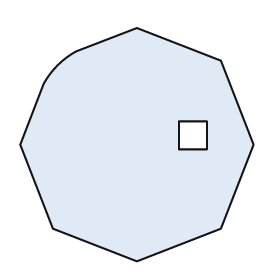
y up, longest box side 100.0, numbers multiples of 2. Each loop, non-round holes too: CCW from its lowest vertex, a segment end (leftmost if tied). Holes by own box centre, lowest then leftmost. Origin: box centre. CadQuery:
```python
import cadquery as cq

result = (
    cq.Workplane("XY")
    .moveTo(0.0, -50.0)
    .lineTo(36.0, -36.0)
    .lineTo(50.0, 0.0)
    .lineTo(36.0, 36.0)
    .lineTo(0.0, 50.0)
    .lineTo(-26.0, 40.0)
    .threePointArc((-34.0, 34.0), (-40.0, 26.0))
    .lineTo(-50.0, 0.0)
    .lineTo(-36.0, -36.0)
    .close()
    .moveTo(18.0, -2.0)
    .lineTo(30.0, -2.0)
    .lineTo(30.0, 10.0)
    .lineTo(18.0, 10.0)
    .close()
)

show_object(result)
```